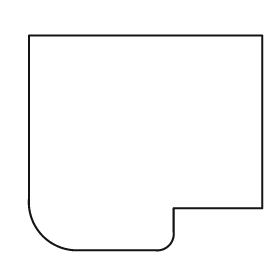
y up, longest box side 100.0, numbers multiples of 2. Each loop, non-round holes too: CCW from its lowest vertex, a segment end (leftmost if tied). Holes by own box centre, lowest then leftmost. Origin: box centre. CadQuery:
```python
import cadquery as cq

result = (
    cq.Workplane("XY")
    .moveTo(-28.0, -46.0)
    .lineTo(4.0, -46.0)
    .threePointArc((10.0, -44.0), (12.0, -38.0))
    .lineTo(12.0, -28.0)
    .lineTo(50.0, -28.0)
    .lineTo(50.0, 46.0)
    .lineTo(-50.0, 46.0)
    .lineTo(-50.0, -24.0)
    .threePointArc((-44.0, -40.0), (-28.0, -46.0))
    .close()
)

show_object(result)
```